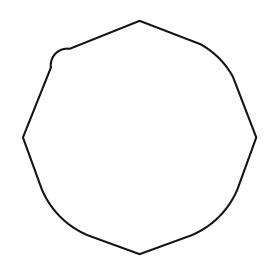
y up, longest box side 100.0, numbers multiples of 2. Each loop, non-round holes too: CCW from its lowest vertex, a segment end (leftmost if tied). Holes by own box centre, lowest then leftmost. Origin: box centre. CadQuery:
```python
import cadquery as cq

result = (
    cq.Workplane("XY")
    .moveTo(0.0, -50.0)
    .lineTo(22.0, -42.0)
    .threePointArc((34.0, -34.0), (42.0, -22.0))
    .lineTo(50.0, 0.0)
    .lineTo(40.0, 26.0)
    .threePointArc((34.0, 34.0), (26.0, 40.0))
    .lineTo(0.0, 50.0)
    .lineTo(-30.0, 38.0)
    .threePointArc((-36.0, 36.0), (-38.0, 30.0))
    .lineTo(-50.0, 0.0)
    .lineTo(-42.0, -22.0)
    .threePointArc((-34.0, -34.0), (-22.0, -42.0))
    .close()
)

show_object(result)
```